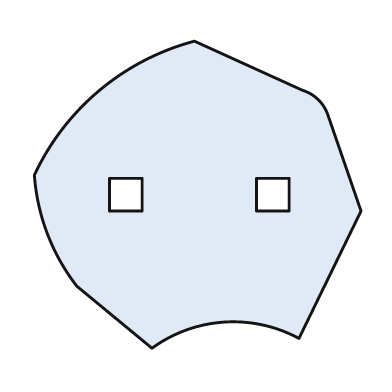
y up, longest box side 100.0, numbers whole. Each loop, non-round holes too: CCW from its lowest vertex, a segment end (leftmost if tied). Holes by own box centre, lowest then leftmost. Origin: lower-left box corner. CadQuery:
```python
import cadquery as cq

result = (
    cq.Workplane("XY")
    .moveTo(36.0, 0.0)
    .threePointArc((58.0, 8.0), (81.0, 3.0))
    .lineTo(100.0, 42.0)
    .lineTo(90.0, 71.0)
    .threePointArc((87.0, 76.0), (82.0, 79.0))
    .lineTo(49.0, 94.0)
    .threePointArc((20.0, 79.0), (0.0, 53.0))
    .threePointArc((4.0, 35.0), (13.0, 19.0))
    .close()
    .moveTo(23.0, 42.0)
    .lineTo(33.0, 42.0)
    .lineTo(33.0, 52.0)
    .lineTo(23.0, 52.0)
    .close()
    .moveTo(68.0, 42.0)
    .lineTo(78.0, 42.0)
    .lineTo(78.0, 52.0)
    .lineTo(68.0, 52.0)
    .close()
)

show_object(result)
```